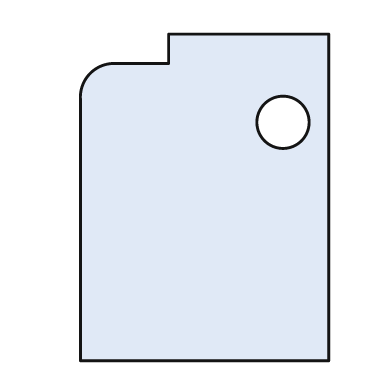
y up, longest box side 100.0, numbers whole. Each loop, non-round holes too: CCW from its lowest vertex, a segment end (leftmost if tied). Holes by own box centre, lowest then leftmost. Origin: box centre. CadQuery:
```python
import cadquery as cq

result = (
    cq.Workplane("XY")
    .moveTo(-38.0, -50.0)
    .lineTo(38.0, -50.0)
    .lineTo(38.0, 50.0)
    .lineTo(-11.0, 50.0)
    .lineTo(-11.0, 41.0)
    .lineTo(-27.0, 41.0)
    .threePointArc((-35.0, 38.0), (-38.0, 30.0))
    .close()
    .moveTo(24.0, 23.0)
    .circle(8.0)
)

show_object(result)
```